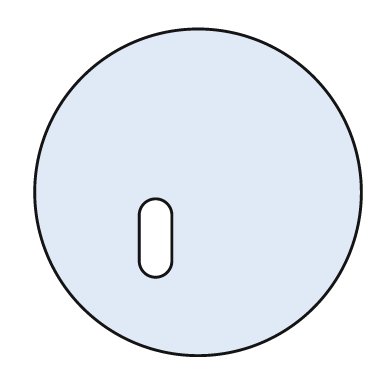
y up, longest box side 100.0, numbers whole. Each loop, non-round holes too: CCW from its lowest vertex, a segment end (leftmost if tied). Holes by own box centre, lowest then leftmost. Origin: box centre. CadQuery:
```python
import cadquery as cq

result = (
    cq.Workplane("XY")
    .moveTo(0.0, 0.0)
    .circle(50.0)
    .moveTo(-18.0, -21.0)
    .threePointArc((-13.0, -26.0), (-8.0, -21.0))
    .lineTo(-8.0, -7.0)
    .threePointArc((-13.0, -2.0), (-18.0, -7.0))
    .close()
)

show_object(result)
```